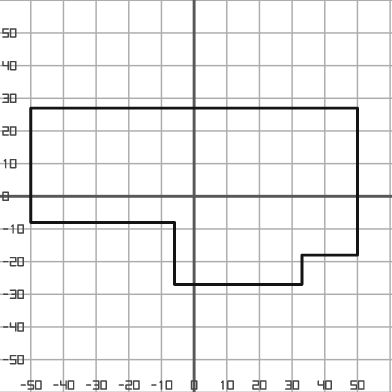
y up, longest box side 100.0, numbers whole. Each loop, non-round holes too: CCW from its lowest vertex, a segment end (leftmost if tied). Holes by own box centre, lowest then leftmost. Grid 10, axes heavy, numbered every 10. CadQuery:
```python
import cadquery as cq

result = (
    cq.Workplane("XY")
    .moveTo(-6.0, -27.0)
    .lineTo(33.0, -27.0)
    .lineTo(33.0, -18.0)
    .lineTo(50.0, -18.0)
    .lineTo(50.0, 27.0)
    .lineTo(-50.0, 27.0)
    .lineTo(-50.0, -8.0)
    .lineTo(-6.0, -8.0)
    .close()
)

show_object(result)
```